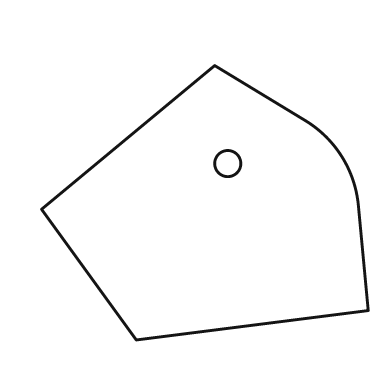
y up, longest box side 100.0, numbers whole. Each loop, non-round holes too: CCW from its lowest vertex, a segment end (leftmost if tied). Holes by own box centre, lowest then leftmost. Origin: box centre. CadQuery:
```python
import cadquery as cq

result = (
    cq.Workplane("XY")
    .moveTo(-21.0, -42.0)
    .lineTo(50.0, -33.0)
    .lineTo(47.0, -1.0)
    .threePointArc((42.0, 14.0), (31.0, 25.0))
    .lineTo(3.0, 42.0)
    .lineTo(-50.0, -2.0)
    .close()
    .moveTo(7.0, 12.0)
    .circle(4.0)
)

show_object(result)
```